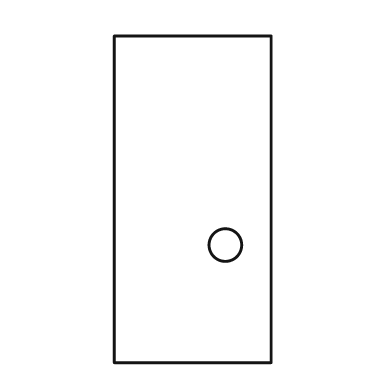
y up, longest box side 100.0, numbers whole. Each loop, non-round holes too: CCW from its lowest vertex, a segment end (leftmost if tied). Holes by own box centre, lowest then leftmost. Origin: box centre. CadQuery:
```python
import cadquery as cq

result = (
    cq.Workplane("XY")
    .moveTo(-24.0, -50.0)
    .lineTo(24.0, -50.0)
    .lineTo(24.0, 50.0)
    .lineTo(-24.0, 50.0)
    .close()
    .moveTo(10.0, -14.0)
    .circle(5.0)
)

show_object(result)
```